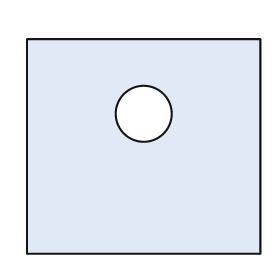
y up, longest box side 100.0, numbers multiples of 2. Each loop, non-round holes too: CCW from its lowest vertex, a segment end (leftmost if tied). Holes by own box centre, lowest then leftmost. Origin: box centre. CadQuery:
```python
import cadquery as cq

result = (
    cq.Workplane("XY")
    .moveTo(-50.0, -46.0)
    .lineTo(50.0, -46.0)
    .lineTo(50.0, 46.0)
    .lineTo(-50.0, 46.0)
    .close()
    .moveTo(0.0, 14.0)
    .circle(12.0)
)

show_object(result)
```